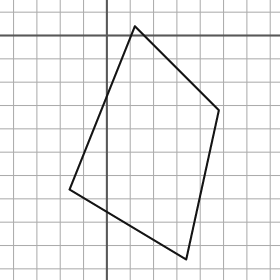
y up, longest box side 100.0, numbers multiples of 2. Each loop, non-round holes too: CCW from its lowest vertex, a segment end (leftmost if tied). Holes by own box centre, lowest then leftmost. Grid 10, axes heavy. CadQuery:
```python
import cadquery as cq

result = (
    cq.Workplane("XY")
    .moveTo(34.0, -96.0)
    .lineTo(48.0, -32.0)
    .lineTo(12.0, 4.0)
    .lineTo(-16.0, -66.0)
    .close()
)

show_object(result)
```